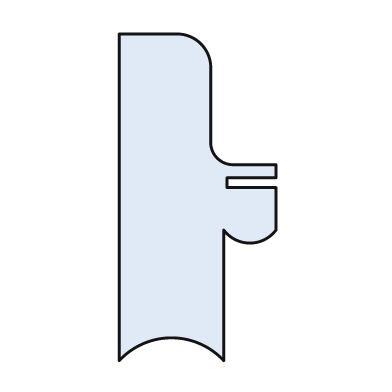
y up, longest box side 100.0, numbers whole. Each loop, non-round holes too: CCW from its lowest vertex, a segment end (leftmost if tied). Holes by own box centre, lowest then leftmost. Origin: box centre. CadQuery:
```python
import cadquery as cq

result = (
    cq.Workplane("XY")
    .moveTo(-24.0, -50.0)
    .threePointArc((-8.0, -43.0), (8.0, -50.0))
    .lineTo(8.0, -10.0)
    .threePointArc((16.0, -14.0), (24.0, -10.0))
    .lineTo(24.0, 3.0)
    .lineTo(9.0, 3.0)
    .lineTo(9.0, 6.0)
    .lineTo(24.0, 6.0)
    .lineTo(24.0, 10.0)
    .lineTo(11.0, 10.0)
    .threePointArc((6.0, 12.0), (4.0, 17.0))
    .lineTo(4.0, 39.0)
    .threePointArc((1.0, 47.0), (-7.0, 50.0))
    .lineTo(-24.0, 50.0)
    .close()
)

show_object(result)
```